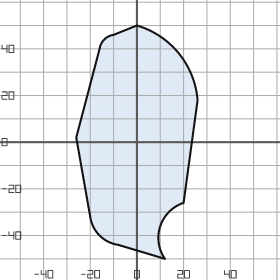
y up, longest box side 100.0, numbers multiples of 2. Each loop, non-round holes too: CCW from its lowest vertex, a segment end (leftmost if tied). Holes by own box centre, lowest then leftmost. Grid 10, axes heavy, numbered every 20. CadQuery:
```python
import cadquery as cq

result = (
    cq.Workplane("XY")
    .moveTo(12.0, -50.0)
    .threePointArc((10.0, -36.0), (20.0, -26.0))
    .lineTo(26.0, 18.0)
    .threePointArc((18.0, 38.0), (0.0, 50.0))
    .lineTo(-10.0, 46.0)
    .threePointArc((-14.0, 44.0), (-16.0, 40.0))
    .lineTo(-26.0, 2.0)
    .lineTo(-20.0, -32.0)
    .threePointArc((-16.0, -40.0), (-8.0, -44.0))
    .close()
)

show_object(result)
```